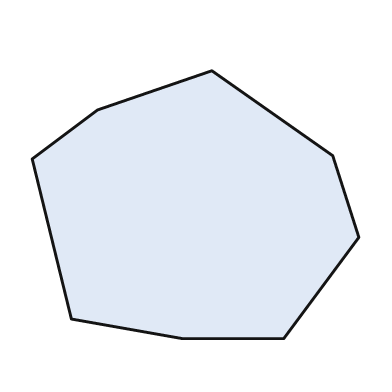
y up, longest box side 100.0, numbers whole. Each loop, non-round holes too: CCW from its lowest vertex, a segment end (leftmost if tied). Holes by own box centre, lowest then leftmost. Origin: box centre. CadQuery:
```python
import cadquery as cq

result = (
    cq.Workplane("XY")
    .moveTo(-4.0, -41.0)
    .lineTo(27.0, -41.0)
    .lineTo(50.0, -10.0)
    .lineTo(42.0, 15.0)
    .lineTo(5.0, 41.0)
    .lineTo(-30.0, 29.0)
    .lineTo(-50.0, 14.0)
    .lineTo(-38.0, -35.0)
    .close()
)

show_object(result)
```